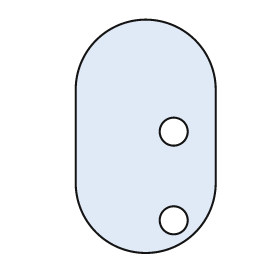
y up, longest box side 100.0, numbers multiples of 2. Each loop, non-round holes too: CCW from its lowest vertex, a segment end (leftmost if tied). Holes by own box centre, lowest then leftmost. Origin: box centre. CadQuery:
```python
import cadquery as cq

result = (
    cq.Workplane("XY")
    .moveTo(-30.0, -20.0)
    .threePointArc((0.0, -50.0), (30.0, -20.0))
    .lineTo(30.0, 20.0)
    .threePointArc((0.0, 50.0), (-30.0, 20.0))
    .close()
    .moveTo(12.0, -36.0)
    .circle(6.0)
    .moveTo(12.0, 2.0)
    .circle(6.0)
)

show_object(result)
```